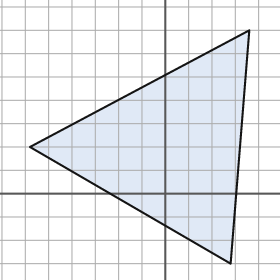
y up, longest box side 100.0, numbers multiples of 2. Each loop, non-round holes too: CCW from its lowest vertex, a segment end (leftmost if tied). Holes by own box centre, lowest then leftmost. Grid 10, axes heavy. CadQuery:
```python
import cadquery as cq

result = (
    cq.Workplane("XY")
    .moveTo(28.0, -30.0)
    .lineTo(36.0, 70.0)
    .lineTo(-58.0, 20.0)
    .close()
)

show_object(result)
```